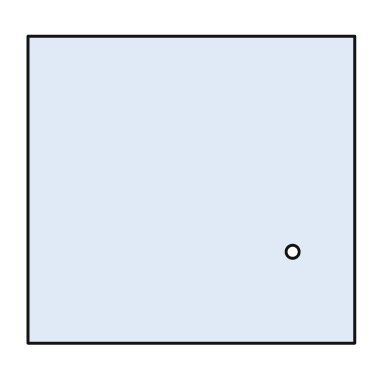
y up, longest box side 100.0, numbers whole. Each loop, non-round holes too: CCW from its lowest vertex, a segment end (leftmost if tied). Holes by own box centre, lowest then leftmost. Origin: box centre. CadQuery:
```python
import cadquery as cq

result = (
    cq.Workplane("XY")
    .moveTo(-50.0, -47.0)
    .lineTo(50.0, -47.0)
    .lineTo(50.0, 47.0)
    .lineTo(-50.0, 47.0)
    .close()
    .moveTo(31.0, -19.0)
    .circle(2.0)
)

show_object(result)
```